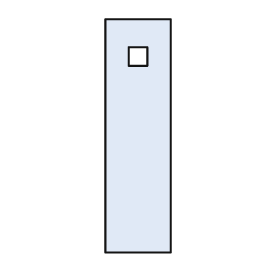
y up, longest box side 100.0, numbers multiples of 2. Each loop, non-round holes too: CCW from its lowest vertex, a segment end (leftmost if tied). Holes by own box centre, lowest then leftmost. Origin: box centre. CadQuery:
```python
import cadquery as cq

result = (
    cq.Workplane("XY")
    .moveTo(-14.0, -50.0)
    .lineTo(14.0, -50.0)
    .lineTo(14.0, 50.0)
    .lineTo(-14.0, 50.0)
    .close()
    .moveTo(-4.0, 30.0)
    .lineTo(4.0, 30.0)
    .lineTo(4.0, 38.0)
    .lineTo(-4.0, 38.0)
    .close()
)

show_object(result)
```